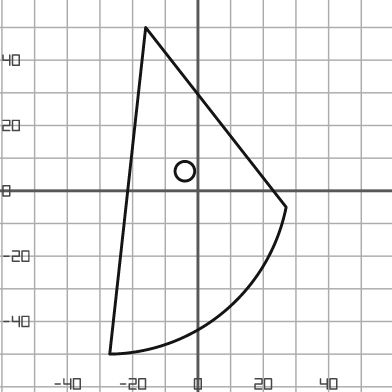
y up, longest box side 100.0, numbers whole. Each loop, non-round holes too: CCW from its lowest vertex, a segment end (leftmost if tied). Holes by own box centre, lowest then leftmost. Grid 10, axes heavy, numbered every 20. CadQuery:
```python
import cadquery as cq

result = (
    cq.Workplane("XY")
    .moveTo(-27.0, -50.0)
    .threePointArc((8.0, -37.0), (27.0, -5.0))
    .lineTo(-16.0, 50.0)
    .close()
    .moveTo(-4.0, 6.0)
    .circle(3.0)
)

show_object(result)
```